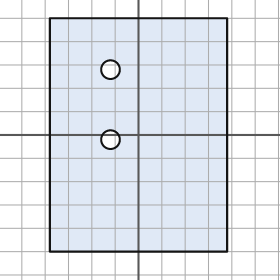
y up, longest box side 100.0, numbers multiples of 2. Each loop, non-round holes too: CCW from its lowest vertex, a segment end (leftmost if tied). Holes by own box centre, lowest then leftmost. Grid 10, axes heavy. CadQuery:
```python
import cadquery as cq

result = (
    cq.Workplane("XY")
    .moveTo(-38.0, -50.0)
    .lineTo(38.0, -50.0)
    .lineTo(38.0, 50.0)
    .lineTo(-38.0, 50.0)
    .close()
    .moveTo(-12.0, -2.0)
    .circle(4.0)
    .moveTo(-12.0, 28.0)
    .circle(4.0)
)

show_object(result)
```